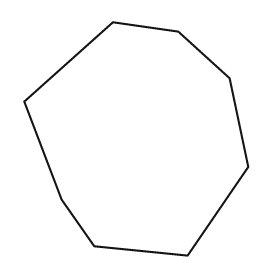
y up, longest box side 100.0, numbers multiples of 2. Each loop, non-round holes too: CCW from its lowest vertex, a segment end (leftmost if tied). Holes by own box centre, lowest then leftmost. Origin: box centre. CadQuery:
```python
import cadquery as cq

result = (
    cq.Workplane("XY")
    .moveTo(22.0, -50.0)
    .lineTo(48.0, -12.0)
    .lineTo(40.0, 26.0)
    .lineTo(18.0, 46.0)
    .lineTo(-10.0, 50.0)
    .lineTo(-48.0, 16.0)
    .lineTo(-32.0, -26.0)
    .lineTo(-18.0, -46.0)
    .close()
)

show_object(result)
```